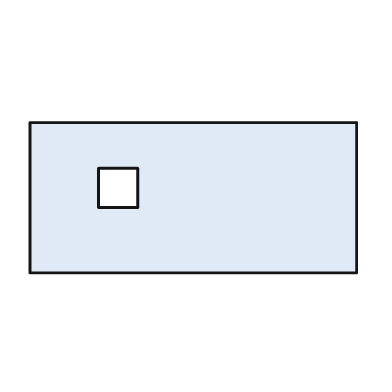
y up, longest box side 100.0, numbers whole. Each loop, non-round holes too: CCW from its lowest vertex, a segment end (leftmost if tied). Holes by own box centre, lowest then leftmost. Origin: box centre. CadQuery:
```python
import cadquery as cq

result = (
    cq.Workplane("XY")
    .moveTo(-50.0, -23.0)
    .lineTo(50.0, -23.0)
    .lineTo(50.0, 23.0)
    .lineTo(-50.0, 23.0)
    .close()
    .moveTo(-29.0, -3.0)
    .lineTo(-17.0, -3.0)
    .lineTo(-17.0, 9.0)
    .lineTo(-29.0, 9.0)
    .close()
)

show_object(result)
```